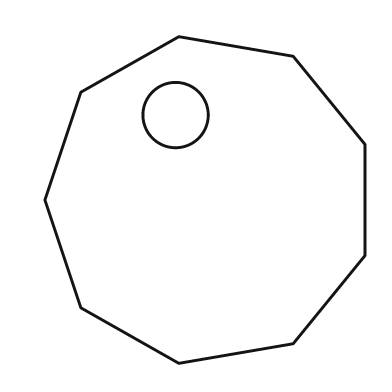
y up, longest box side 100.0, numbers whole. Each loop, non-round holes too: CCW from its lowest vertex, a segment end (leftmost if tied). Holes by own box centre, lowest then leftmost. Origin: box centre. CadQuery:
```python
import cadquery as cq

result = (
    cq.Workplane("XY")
    .moveTo(-8.0, -50.0)
    .lineTo(27.0, -44.0)
    .lineTo(49.0, -17.0)
    .lineTo(49.0, 17.0)
    .lineTo(27.0, 44.0)
    .lineTo(-8.0, 50.0)
    .lineTo(-38.0, 33.0)
    .lineTo(-49.0, 0.0)
    .lineTo(-38.0, -33.0)
    .close()
    .moveTo(-9.0, 26.0)
    .circle(10.0)
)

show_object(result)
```